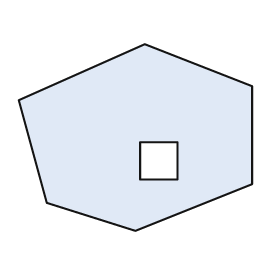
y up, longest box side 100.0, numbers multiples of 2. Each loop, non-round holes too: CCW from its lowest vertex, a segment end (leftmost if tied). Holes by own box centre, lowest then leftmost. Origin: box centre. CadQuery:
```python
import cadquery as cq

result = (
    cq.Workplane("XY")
    .moveTo(0.0, -40.0)
    .lineTo(50.0, -20.0)
    .lineTo(50.0, 22.0)
    .lineTo(4.0, 40.0)
    .lineTo(-50.0, 16.0)
    .lineTo(-38.0, -28.0)
    .close()
    .moveTo(2.0, -18.0)
    .lineTo(18.0, -18.0)
    .lineTo(18.0, -2.0)
    .lineTo(2.0, -2.0)
    .close()
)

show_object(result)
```